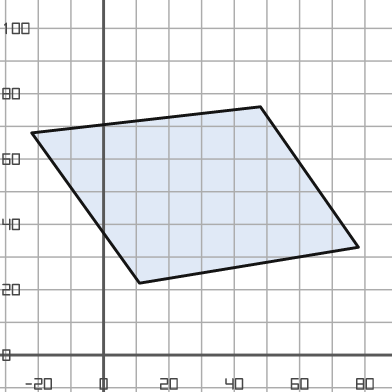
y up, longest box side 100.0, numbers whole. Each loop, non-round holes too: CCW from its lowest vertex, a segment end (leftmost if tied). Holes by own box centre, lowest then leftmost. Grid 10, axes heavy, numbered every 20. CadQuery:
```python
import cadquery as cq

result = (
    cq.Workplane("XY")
    .moveTo(11.0, 22.0)
    .lineTo(78.0, 33.0)
    .lineTo(48.0, 76.0)
    .lineTo(-22.0, 68.0)
    .close()
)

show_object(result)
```